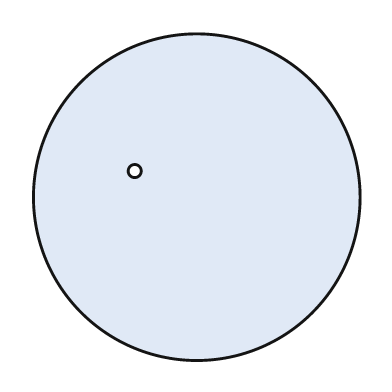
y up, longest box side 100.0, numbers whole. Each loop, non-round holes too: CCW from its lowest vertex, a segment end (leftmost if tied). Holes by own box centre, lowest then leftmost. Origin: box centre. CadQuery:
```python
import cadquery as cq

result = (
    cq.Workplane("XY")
    .moveTo(0.0, 0.0)
    .circle(50.0)
    .moveTo(-19.0, 8.0)
    .circle(2.0)
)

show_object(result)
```